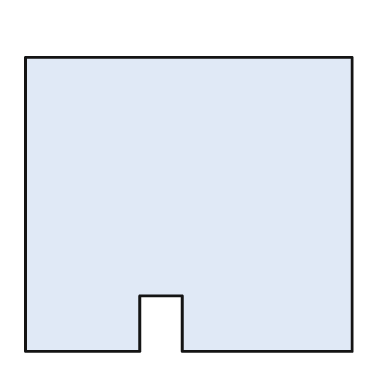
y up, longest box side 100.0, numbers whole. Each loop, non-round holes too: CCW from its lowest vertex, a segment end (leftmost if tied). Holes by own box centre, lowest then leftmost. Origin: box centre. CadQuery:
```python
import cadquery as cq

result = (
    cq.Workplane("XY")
    .moveTo(-50.0, -45.0)
    .lineTo(-15.0, -45.0)
    .lineTo(-15.0, -28.0)
    .lineTo(-2.0, -28.0)
    .lineTo(-2.0, -45.0)
    .lineTo(50.0, -45.0)
    .lineTo(50.0, 45.0)
    .lineTo(-50.0, 45.0)
    .close()
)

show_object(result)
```